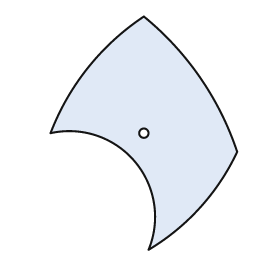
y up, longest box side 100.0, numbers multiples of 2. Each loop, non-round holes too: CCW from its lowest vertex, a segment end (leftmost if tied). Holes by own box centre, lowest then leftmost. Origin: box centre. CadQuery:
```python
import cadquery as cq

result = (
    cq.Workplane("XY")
    .moveTo(2.0, -50.0)
    .threePointArc((24.0, -32.0), (40.0, -8.0))
    .threePointArc((24.0, 24.0), (0.0, 50.0))
    .threePointArc((-24.0, 28.0), (-40.0, 0.0))
    .threePointArc((-4.0, -12.0), (2.0, -50.0))
    .close()
    .moveTo(0.0, 0.0)
    .circle(2.0)
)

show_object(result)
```